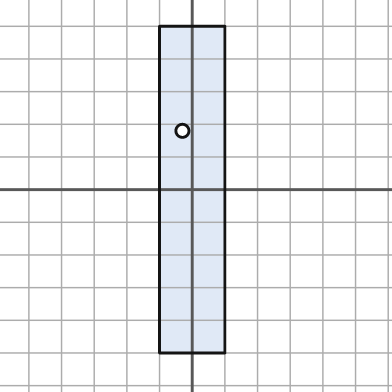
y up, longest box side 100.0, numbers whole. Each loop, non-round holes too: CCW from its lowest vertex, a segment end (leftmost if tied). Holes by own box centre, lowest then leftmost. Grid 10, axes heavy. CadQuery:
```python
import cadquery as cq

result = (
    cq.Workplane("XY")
    .moveTo(-10.0, -50.0)
    .lineTo(10.0, -50.0)
    .lineTo(10.0, 50.0)
    .lineTo(-10.0, 50.0)
    .close()
    .moveTo(-3.0, 18.0)
    .circle(2.0)
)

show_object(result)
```